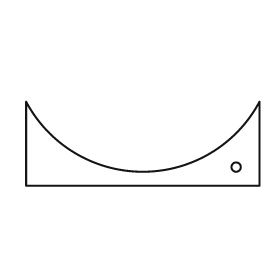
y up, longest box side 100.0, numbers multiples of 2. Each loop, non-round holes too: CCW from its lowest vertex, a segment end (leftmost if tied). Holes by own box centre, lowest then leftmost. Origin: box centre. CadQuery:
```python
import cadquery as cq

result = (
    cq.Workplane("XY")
    .moveTo(-50.0, -18.0)
    .lineTo(50.0, -18.0)
    .lineTo(50.0, 18.0)
    .threePointArc((0.0, -12.0), (-50.0, 18.0))
    .close()
    .moveTo(40.0, -10.0)
    .circle(2.0)
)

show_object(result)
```